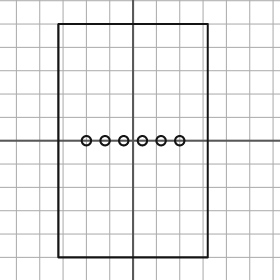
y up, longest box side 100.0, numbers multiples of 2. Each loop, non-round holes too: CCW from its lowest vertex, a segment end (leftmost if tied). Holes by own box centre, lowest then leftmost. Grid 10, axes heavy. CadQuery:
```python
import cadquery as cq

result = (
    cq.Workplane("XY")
    .moveTo(-32.0, -50.0)
    .lineTo(32.0, -50.0)
    .lineTo(32.0, 50.0)
    .lineTo(-32.0, 50.0)
    .close()
    .moveTo(-20.0, 0.0)
    .circle(2.0)
    .moveTo(-12.0, 0.0)
    .circle(2.0)
    .moveTo(-4.0, 0.0)
    .circle(2.0)
    .moveTo(4.0, 0.0)
    .circle(2.0)
    .moveTo(12.0, 0.0)
    .circle(2.0)
    .moveTo(20.0, 0.0)
    .circle(2.0)
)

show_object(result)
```